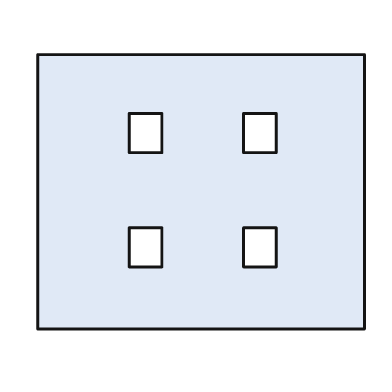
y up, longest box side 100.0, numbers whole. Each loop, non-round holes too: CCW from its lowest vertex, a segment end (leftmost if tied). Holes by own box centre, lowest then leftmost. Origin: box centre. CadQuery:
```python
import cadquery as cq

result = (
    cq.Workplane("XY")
    .moveTo(-50.0, -42.0)
    .lineTo(50.0, -42.0)
    .lineTo(50.0, 42.0)
    .lineTo(-50.0, 42.0)
    .close()
    .moveTo(-22.0, -23.0)
    .lineTo(-12.0, -23.0)
    .lineTo(-12.0, -11.0)
    .lineTo(-22.0, -11.0)
    .close()
    .moveTo(13.0, -23.0)
    .lineTo(23.0, -23.0)
    .lineTo(23.0, -11.0)
    .lineTo(13.0, -11.0)
    .close()
    .moveTo(-22.0, 12.0)
    .lineTo(-12.0, 12.0)
    .lineTo(-12.0, 24.0)
    .lineTo(-22.0, 24.0)
    .close()
    .moveTo(13.0, 12.0)
    .lineTo(23.0, 12.0)
    .lineTo(23.0, 24.0)
    .lineTo(13.0, 24.0)
    .close()
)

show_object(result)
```